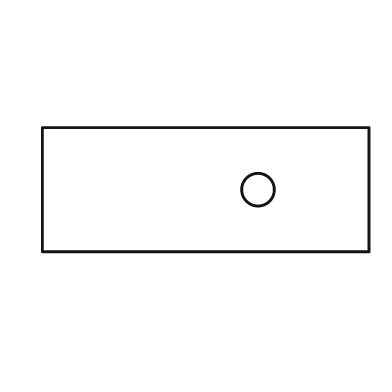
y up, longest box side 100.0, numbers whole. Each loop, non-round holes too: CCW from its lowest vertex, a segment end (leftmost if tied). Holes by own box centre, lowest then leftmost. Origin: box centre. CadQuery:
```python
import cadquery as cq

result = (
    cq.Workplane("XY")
    .moveTo(-50.0, -19.0)
    .lineTo(50.0, -19.0)
    .lineTo(50.0, 19.0)
    .lineTo(-50.0, 19.0)
    .close()
    .moveTo(16.0, 0.0)
    .circle(5.0)
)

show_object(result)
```